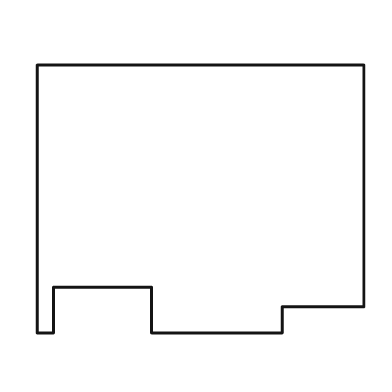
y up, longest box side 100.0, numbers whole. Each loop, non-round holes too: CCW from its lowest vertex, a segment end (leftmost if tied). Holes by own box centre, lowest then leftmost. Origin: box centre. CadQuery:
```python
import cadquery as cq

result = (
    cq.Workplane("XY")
    .moveTo(-50.0, -41.0)
    .lineTo(-45.0, -41.0)
    .lineTo(-45.0, -27.0)
    .lineTo(-15.0, -27.0)
    .lineTo(-15.0, -41.0)
    .lineTo(25.0, -41.0)
    .lineTo(25.0, -33.0)
    .lineTo(50.0, -33.0)
    .lineTo(50.0, 41.0)
    .lineTo(-50.0, 41.0)
    .close()
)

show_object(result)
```